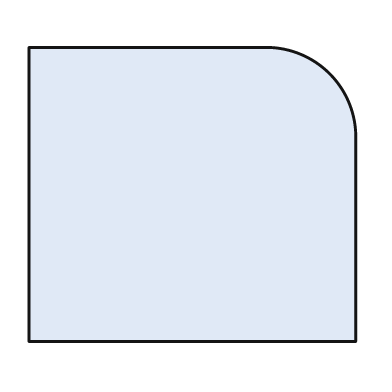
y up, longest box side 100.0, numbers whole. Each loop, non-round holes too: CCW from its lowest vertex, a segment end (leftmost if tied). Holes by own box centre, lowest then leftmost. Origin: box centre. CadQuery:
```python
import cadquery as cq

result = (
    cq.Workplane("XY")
    .moveTo(-50.0, -45.0)
    .lineTo(50.0, -45.0)
    .lineTo(50.0, 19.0)
    .threePointArc((42.0, 37.0), (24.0, 45.0))
    .lineTo(-50.0, 45.0)
    .close()
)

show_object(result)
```